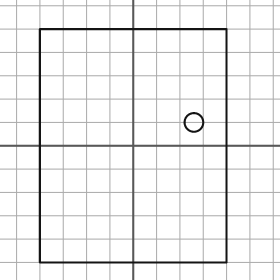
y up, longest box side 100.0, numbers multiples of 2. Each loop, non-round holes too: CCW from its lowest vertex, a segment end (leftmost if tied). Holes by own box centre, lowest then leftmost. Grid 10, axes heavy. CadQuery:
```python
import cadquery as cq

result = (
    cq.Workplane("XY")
    .moveTo(-40.0, -50.0)
    .lineTo(40.0, -50.0)
    .lineTo(40.0, 50.0)
    .lineTo(-40.0, 50.0)
    .close()
    .moveTo(26.0, 10.0)
    .circle(4.0)
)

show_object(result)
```